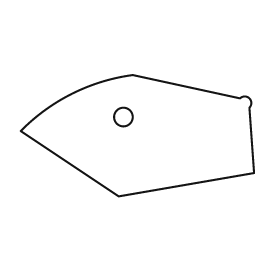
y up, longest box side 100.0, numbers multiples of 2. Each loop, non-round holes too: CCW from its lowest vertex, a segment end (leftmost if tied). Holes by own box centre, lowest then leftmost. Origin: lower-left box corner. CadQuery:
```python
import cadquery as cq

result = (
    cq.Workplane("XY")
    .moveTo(42.0, 0.0)
    .lineTo(100.0, 10.0)
    .lineTo(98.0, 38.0)
    .threePointArc((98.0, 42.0), (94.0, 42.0))
    .lineTo(48.0, 52.0)
    .threePointArc((22.0, 44.0), (0.0, 28.0))
    .close()
    .moveTo(44.0, 34.0)
    .circle(4.0)
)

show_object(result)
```